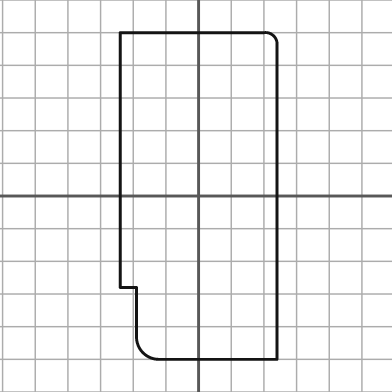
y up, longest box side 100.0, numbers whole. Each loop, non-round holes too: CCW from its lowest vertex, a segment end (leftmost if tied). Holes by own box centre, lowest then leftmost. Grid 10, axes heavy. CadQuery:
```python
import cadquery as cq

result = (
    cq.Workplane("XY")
    .moveTo(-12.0, -50.0)
    .lineTo(24.0, -50.0)
    .lineTo(24.0, 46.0)
    .threePointArc((23.0, 49.0), (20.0, 50.0))
    .lineTo(-24.0, 50.0)
    .lineTo(-24.0, -28.0)
    .lineTo(-19.0, -28.0)
    .lineTo(-19.0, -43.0)
    .threePointArc((-17.0, -48.0), (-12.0, -50.0))
    .close()
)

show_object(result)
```